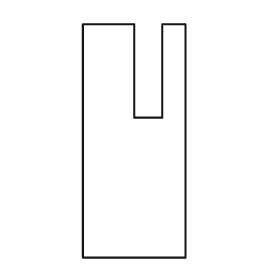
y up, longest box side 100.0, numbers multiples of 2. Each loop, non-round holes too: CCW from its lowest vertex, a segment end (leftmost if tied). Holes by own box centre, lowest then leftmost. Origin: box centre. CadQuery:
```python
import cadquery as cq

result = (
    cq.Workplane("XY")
    .moveTo(-22.0, -50.0)
    .lineTo(22.0, -50.0)
    .lineTo(22.0, 50.0)
    .lineTo(12.0, 50.0)
    .lineTo(12.0, 10.0)
    .lineTo(0.0, 10.0)
    .lineTo(0.0, 50.0)
    .lineTo(-22.0, 50.0)
    .close()
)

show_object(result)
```